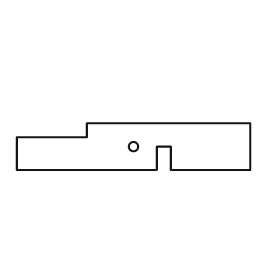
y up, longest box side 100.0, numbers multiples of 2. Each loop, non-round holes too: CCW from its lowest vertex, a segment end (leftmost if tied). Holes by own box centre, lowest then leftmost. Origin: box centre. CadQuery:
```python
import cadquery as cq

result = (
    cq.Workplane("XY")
    .moveTo(-50.0, -10.0)
    .lineTo(10.0, -10.0)
    .lineTo(10.0, 0.0)
    .lineTo(16.0, 0.0)
    .lineTo(16.0, -10.0)
    .lineTo(50.0, -10.0)
    .lineTo(50.0, 10.0)
    .lineTo(-20.0, 10.0)
    .lineTo(-20.0, 4.0)
    .lineTo(-50.0, 4.0)
    .close()
    .moveTo(0.0, 0.0)
    .circle(2.0)
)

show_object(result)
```